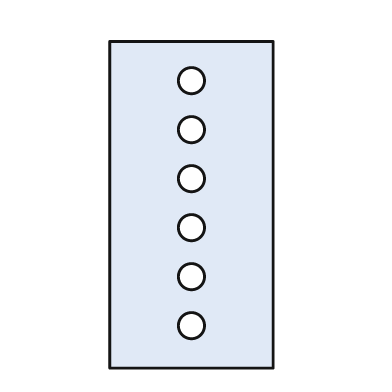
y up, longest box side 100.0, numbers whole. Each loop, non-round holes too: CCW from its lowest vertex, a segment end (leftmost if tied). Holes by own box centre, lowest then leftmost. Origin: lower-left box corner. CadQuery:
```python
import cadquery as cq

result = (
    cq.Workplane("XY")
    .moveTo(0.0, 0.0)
    .lineTo(50.0, 0.0)
    .lineTo(50.0, 100.0)
    .lineTo(0.0, 100.0)
    .close()
    .moveTo(25.0, 13.0)
    .circle(4.0)
    .moveTo(25.0, 28.0)
    .circle(4.0)
    .moveTo(25.0, 43.0)
    .circle(4.0)
    .moveTo(25.0, 58.0)
    .circle(4.0)
    .moveTo(25.0, 73.0)
    .circle(4.0)
    .moveTo(25.0, 88.0)
    .circle(4.0)
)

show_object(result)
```